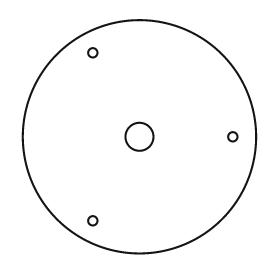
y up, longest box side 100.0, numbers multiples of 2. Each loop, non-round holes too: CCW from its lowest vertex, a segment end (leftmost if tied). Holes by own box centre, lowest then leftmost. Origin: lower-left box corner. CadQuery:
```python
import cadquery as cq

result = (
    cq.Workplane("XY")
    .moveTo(50.0, 50.0)
    .circle(50.0)
    .moveTo(30.0, 14.0)
    .circle(2.0)
    .moveTo(50.0, 50.0)
    .circle(6.0)
    .moveTo(90.0, 50.0)
    .circle(2.0)
    .moveTo(30.0, 86.0)
    .circle(2.0)
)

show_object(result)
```